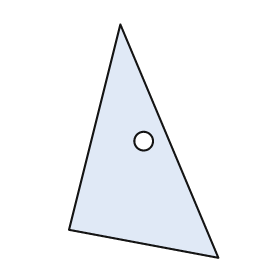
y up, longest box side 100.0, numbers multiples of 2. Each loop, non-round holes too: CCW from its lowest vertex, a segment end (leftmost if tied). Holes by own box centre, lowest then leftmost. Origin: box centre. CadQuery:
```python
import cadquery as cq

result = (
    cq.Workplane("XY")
    .moveTo(32.0, -50.0)
    .lineTo(-10.0, 50.0)
    .lineTo(-32.0, -38.0)
    .close()
    .moveTo(0.0, 0.0)
    .circle(4.0)
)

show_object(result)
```